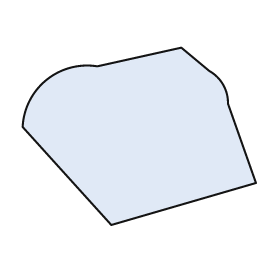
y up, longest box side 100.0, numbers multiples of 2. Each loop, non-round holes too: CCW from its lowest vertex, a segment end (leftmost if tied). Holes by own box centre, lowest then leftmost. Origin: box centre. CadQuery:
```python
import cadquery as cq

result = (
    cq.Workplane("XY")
    .moveTo(-12.0, -38.0)
    .lineTo(50.0, -20.0)
    .lineTo(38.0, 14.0)
    .threePointArc((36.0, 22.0), (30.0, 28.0))
    .lineTo(18.0, 38.0)
    .lineTo(-18.0, 30.0)
    .threePointArc((-40.0, 24.0), (-50.0, 4.0))
    .close()
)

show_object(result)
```